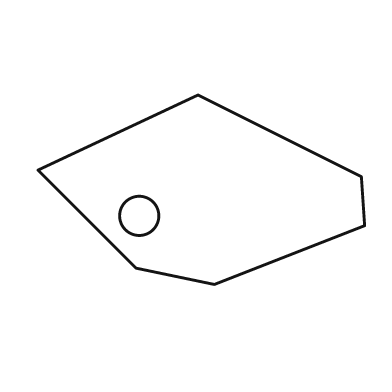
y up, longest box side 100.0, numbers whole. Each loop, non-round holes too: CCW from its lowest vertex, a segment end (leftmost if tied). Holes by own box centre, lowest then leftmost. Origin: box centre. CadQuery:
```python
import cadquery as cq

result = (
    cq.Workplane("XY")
    .moveTo(4.0, -29.0)
    .lineTo(50.0, -11.0)
    .lineTo(49.0, 4.0)
    .lineTo(-1.0, 29.0)
    .lineTo(-50.0, 6.0)
    .lineTo(-20.0, -24.0)
    .close()
    .moveTo(-19.0, -8.0)
    .circle(6.0)
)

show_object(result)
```